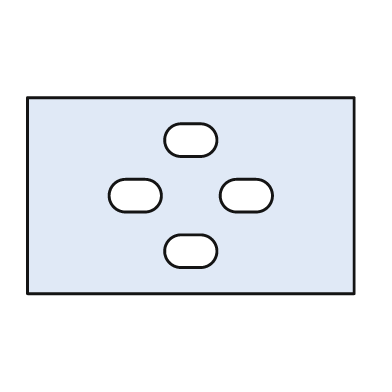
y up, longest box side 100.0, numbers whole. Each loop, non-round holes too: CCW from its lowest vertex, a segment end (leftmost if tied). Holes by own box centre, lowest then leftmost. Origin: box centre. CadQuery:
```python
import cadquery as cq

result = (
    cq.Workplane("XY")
    .moveTo(-50.0, -30.0)
    .lineTo(50.0, -30.0)
    .lineTo(50.0, 30.0)
    .lineTo(-50.0, 30.0)
    .close()
    .moveTo(-3.0, -22.0)
    .lineTo(3.0, -22.0)
    .threePointArc((8.0, -17.0), (3.0, -12.0))
    .lineTo(-3.0, -12.0)
    .threePointArc((-8.0, -17.0), (-3.0, -22.0))
    .close()
    .moveTo(-20.0, -5.0)
    .lineTo(-14.0, -5.0)
    .threePointArc((-9.0, 0.0), (-14.0, 5.0))
    .lineTo(-20.0, 5.0)
    .threePointArc((-25.0, 0.0), (-20.0, -5.0))
    .close()
    .moveTo(14.0, -5.0)
    .lineTo(20.0, -5.0)
    .threePointArc((25.0, 0.0), (20.0, 5.0))
    .lineTo(14.0, 5.0)
    .threePointArc((9.0, 0.0), (14.0, -5.0))
    .close()
    .moveTo(-3.0, 12.0)
    .lineTo(3.0, 12.0)
    .threePointArc((8.0, 17.0), (3.0, 22.0))
    .lineTo(-3.0, 22.0)
    .threePointArc((-8.0, 17.0), (-3.0, 12.0))
    .close()
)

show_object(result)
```